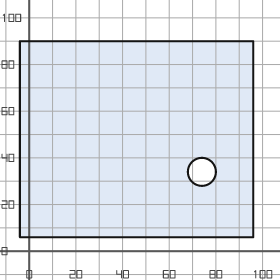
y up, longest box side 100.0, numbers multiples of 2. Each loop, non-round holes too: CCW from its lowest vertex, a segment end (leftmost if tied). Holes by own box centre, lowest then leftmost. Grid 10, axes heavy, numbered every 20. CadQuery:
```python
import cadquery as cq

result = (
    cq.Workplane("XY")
    .moveTo(-4.0, 6.0)
    .lineTo(96.0, 6.0)
    .lineTo(96.0, 90.0)
    .lineTo(-4.0, 90.0)
    .close()
    .moveTo(74.0, 34.0)
    .circle(6.0)
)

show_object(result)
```